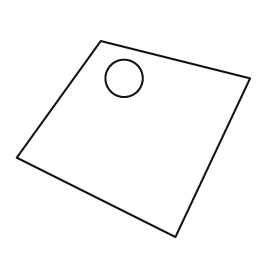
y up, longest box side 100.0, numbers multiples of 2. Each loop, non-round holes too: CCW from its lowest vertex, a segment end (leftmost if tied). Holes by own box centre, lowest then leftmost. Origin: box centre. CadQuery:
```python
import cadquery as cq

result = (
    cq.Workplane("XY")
    .moveTo(18.0, -42.0)
    .lineTo(50.0, 26.0)
    .lineTo(-14.0, 42.0)
    .lineTo(-50.0, -8.0)
    .close()
    .moveTo(-4.0, 26.0)
    .circle(8.0)
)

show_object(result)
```